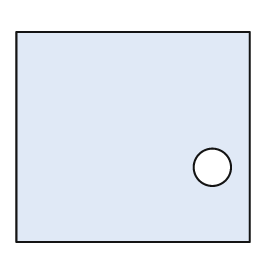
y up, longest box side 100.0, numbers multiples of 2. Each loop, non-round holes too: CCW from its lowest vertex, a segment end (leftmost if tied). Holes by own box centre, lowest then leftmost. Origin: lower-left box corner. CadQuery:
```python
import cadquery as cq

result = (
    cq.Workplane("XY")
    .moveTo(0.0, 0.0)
    .lineTo(100.0, 0.0)
    .lineTo(100.0, 90.0)
    .lineTo(0.0, 90.0)
    .close()
    .moveTo(84.0, 32.0)
    .circle(8.0)
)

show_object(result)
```